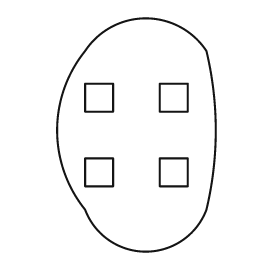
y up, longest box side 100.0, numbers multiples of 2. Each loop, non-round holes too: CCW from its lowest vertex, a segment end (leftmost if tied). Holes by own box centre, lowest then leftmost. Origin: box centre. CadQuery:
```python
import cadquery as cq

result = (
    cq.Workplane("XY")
    .moveTo(-22.0, -32.0)
    .threePointArc((4.0, -50.0), (30.0, -32.0))
    .threePointArc((34.0, 2.0), (30.0, 36.0))
    .threePointArc((4.0, 50.0), (-22.0, 36.0))
    .threePointArc((-34.0, 2.0), (-22.0, -32.0))
    .close()
    .moveTo(-22.0, -22.0)
    .lineTo(-10.0, -22.0)
    .lineTo(-10.0, -10.0)
    .lineTo(-22.0, -10.0)
    .close()
    .moveTo(10.0, -22.0)
    .lineTo(22.0, -22.0)
    .lineTo(22.0, -10.0)
    .lineTo(10.0, -10.0)
    .close()
    .moveTo(-22.0, 10.0)
    .lineTo(-10.0, 10.0)
    .lineTo(-10.0, 22.0)
    .lineTo(-22.0, 22.0)
    .close()
    .moveTo(10.0, 10.0)
    .lineTo(22.0, 10.0)
    .lineTo(22.0, 22.0)
    .lineTo(10.0, 22.0)
    .close()
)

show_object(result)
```